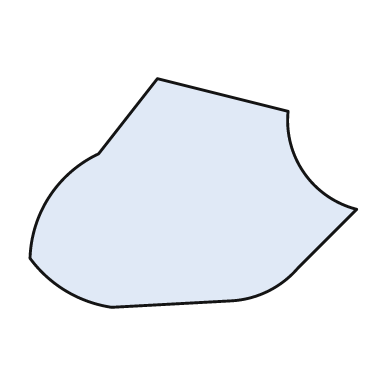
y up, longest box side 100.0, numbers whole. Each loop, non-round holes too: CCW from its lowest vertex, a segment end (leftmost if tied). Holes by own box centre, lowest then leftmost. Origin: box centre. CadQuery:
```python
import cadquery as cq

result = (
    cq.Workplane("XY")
    .moveTo(-25.0, -35.0)
    .lineTo(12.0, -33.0)
    .threePointArc((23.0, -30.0), (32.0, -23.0))
    .lineTo(50.0, -5.0)
    .threePointArc((34.0, 6.0), (29.0, 25.0))
    .lineTo(-11.0, 35.0)
    .lineTo(-29.0, 12.0)
    .threePointArc((-44.0, -1.0), (-50.0, -20.0))
    .threePointArc((-39.0, -30.0), (-25.0, -35.0))
    .close()
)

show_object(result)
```